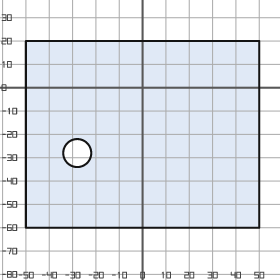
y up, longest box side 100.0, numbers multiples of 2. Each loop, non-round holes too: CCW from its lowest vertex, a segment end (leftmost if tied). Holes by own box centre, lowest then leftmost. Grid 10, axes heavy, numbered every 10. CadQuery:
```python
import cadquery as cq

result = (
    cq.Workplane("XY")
    .moveTo(-50.0, -60.0)
    .lineTo(50.0, -60.0)
    .lineTo(50.0, 20.0)
    .lineTo(-50.0, 20.0)
    .close()
    .moveTo(-28.0, -28.0)
    .circle(6.0)
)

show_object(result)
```